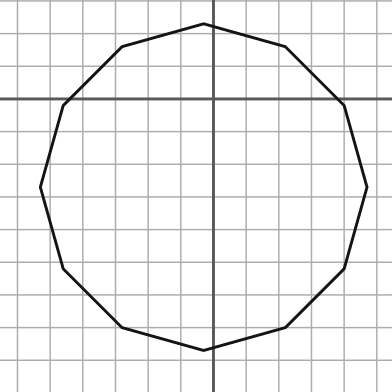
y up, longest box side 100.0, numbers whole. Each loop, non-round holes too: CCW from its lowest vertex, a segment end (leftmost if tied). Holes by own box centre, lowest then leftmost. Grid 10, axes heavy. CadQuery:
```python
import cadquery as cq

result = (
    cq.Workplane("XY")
    .moveTo(-3.0, -77.0)
    .lineTo(22.0, -70.0)
    .lineTo(40.0, -52.0)
    .lineTo(47.0, -27.0)
    .lineTo(40.0, -2.0)
    .lineTo(22.0, 16.0)
    .lineTo(-3.0, 23.0)
    .lineTo(-28.0, 16.0)
    .lineTo(-46.0, -2.0)
    .lineTo(-53.0, -27.0)
    .lineTo(-46.0, -52.0)
    .lineTo(-28.0, -70.0)
    .close()
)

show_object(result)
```